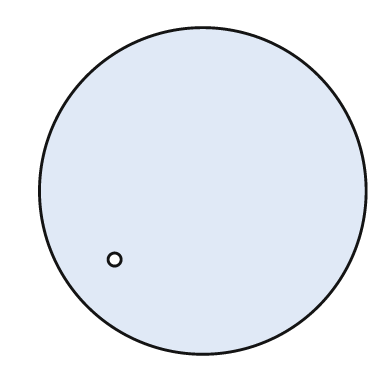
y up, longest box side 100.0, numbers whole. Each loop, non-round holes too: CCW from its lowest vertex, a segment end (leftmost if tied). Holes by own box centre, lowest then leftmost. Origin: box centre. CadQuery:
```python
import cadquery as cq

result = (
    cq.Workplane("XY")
    .moveTo(0.0, 0.0)
    .circle(50.0)
    .moveTo(-27.0, -21.0)
    .circle(2.0)
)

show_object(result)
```